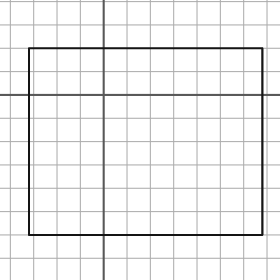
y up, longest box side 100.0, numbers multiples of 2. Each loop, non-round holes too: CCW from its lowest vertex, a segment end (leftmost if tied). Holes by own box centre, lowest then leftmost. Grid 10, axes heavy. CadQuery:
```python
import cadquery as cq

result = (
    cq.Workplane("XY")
    .moveTo(-32.0, -60.0)
    .lineTo(68.0, -60.0)
    .lineTo(68.0, 20.0)
    .lineTo(-32.0, 20.0)
    .close()
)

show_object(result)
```